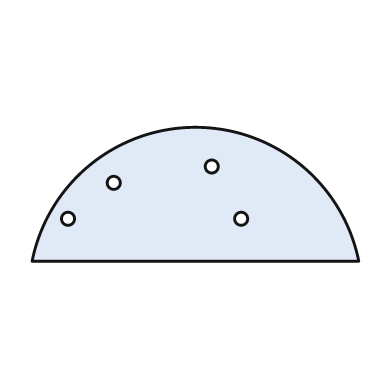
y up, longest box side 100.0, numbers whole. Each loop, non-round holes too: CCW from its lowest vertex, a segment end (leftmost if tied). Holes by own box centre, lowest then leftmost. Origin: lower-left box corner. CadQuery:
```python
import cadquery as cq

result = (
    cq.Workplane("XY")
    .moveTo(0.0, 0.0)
    .lineTo(100.0, 0.0)
    .threePointArc((50.0, 41.0), (0.0, 0.0))
    .close()
    .moveTo(11.0, 13.0)
    .circle(2.0)
    .moveTo(64.0, 13.0)
    .circle(2.0)
    .moveTo(25.0, 24.0)
    .circle(2.0)
    .moveTo(55.0, 29.0)
    .circle(2.0)
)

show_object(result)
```